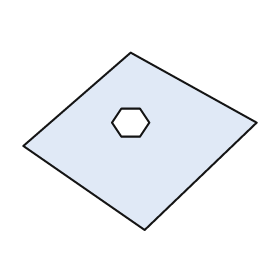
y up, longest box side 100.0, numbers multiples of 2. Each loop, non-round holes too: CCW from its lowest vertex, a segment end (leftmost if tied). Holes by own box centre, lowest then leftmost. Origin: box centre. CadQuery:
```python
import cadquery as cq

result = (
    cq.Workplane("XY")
    .moveTo(2.0, -38.0)
    .lineTo(50.0, 8.0)
    .lineTo(-4.0, 38.0)
    .lineTo(-50.0, -2.0)
    .close()
    .moveTo(-8.0, 2.0)
    .lineTo(0.0, 2.0)
    .lineTo(4.0, 8.0)
    .lineTo(0.0, 14.0)
    .lineTo(-8.0, 14.0)
    .lineTo(-12.0, 8.0)
    .close()
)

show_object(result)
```